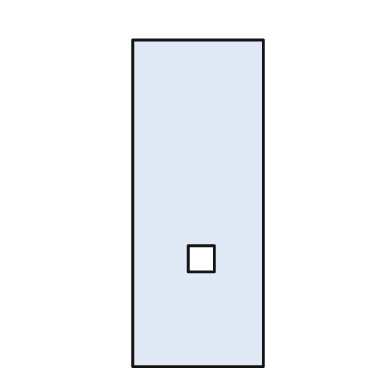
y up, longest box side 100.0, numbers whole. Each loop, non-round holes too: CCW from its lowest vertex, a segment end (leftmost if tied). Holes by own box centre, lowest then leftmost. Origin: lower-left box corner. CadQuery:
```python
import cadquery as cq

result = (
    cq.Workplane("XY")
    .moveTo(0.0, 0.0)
    .lineTo(40.0, 0.0)
    .lineTo(40.0, 100.0)
    .lineTo(0.0, 100.0)
    .close()
    .moveTo(17.0, 29.0)
    .lineTo(25.0, 29.0)
    .lineTo(25.0, 37.0)
    .lineTo(17.0, 37.0)
    .close()
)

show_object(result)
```